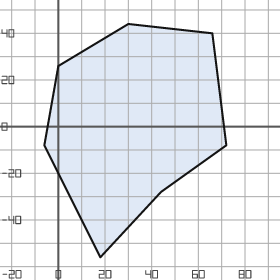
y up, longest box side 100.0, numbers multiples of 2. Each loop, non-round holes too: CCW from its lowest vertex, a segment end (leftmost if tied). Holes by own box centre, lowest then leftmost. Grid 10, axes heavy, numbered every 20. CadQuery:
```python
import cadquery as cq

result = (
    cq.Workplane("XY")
    .moveTo(18.0, -56.0)
    .lineTo(44.0, -28.0)
    .lineTo(72.0, -8.0)
    .lineTo(66.0, 40.0)
    .lineTo(30.0, 44.0)
    .lineTo(0.0, 26.0)
    .lineTo(-6.0, -8.0)
    .close()
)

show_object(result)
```